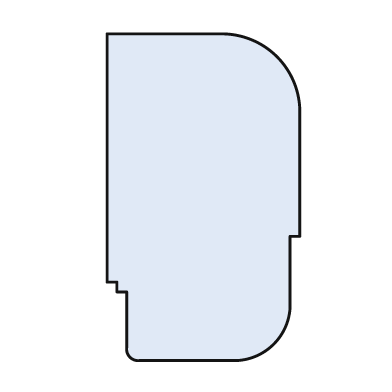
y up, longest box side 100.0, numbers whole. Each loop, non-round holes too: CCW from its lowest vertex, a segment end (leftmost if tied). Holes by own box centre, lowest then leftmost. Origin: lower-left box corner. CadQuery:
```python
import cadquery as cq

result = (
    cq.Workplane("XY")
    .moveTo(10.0, 0.0)
    .lineTo(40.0, 0.0)
    .threePointArc((51.0, 5.0), (56.0, 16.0))
    .lineTo(56.0, 38.0)
    .lineTo(59.0, 38.0)
    .lineTo(59.0, 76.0)
    .threePointArc((52.0, 93.0), (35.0, 100.0))
    .lineTo(0.0, 100.0)
    .lineTo(0.0, 24.0)
    .lineTo(3.0, 24.0)
    .lineTo(3.0, 21.0)
    .lineTo(6.0, 21.0)
    .lineTo(6.0, 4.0)
    .threePointArc((7.0, 1.0), (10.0, 0.0))
    .close()
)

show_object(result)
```